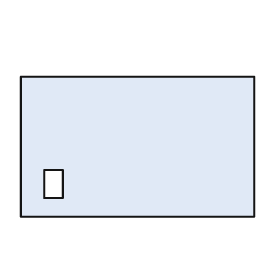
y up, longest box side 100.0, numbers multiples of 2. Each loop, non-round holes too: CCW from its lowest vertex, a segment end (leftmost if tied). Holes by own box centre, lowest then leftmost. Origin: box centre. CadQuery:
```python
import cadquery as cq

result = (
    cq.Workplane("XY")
    .moveTo(-50.0, -30.0)
    .lineTo(50.0, -30.0)
    .lineTo(50.0, 30.0)
    .lineTo(-50.0, 30.0)
    .close()
    .moveTo(-40.0, -22.0)
    .lineTo(-32.0, -22.0)
    .lineTo(-32.0, -10.0)
    .lineTo(-40.0, -10.0)
    .close()
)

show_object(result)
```